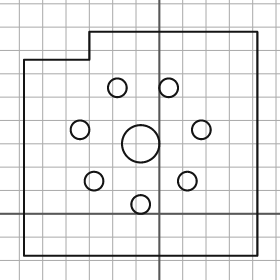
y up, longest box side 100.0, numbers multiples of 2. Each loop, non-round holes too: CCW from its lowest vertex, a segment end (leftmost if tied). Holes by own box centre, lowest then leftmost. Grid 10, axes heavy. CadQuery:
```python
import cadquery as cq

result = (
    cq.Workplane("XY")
    .moveTo(-58.0, -18.0)
    .lineTo(42.0, -18.0)
    .lineTo(42.0, 78.0)
    .lineTo(-30.0, 78.0)
    .lineTo(-30.0, 66.0)
    .lineTo(-58.0, 66.0)
    .close()
    .moveTo(-8.0, 4.0)
    .circle(4.0)
    .moveTo(-28.0, 14.0)
    .circle(4.0)
    .moveTo(12.0, 14.0)
    .circle(4.0)
    .moveTo(-8.0, 30.0)
    .circle(8.0)
    .moveTo(-34.0, 36.0)
    .circle(4.0)
    .moveTo(18.0, 36.0)
    .circle(4.0)
    .moveTo(-18.0, 54.0)
    .circle(4.0)
    .moveTo(4.0, 54.0)
    .circle(4.0)
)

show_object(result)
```